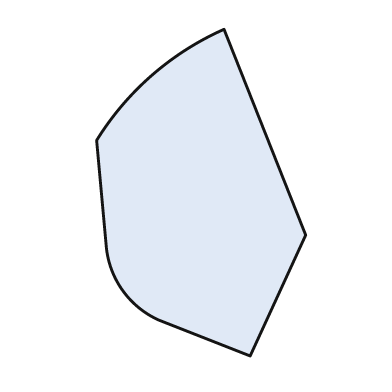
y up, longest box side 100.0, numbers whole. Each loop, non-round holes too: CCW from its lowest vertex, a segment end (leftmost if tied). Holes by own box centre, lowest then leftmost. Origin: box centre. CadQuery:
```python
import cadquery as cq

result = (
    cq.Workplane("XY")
    .moveTo(15.0, -50.0)
    .lineTo(32.0, -13.0)
    .lineTo(7.0, 50.0)
    .threePointArc((-15.0, 36.0), (-32.0, 16.0))
    .lineTo(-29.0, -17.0)
    .threePointArc((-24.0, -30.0), (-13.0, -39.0))
    .close()
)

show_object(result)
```